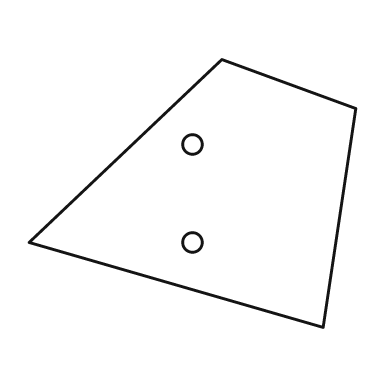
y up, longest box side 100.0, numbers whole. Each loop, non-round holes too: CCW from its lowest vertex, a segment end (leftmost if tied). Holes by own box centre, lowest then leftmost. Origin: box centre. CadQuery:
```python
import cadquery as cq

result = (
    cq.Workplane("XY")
    .moveTo(40.0, -41.0)
    .lineTo(50.0, 26.0)
    .lineTo(9.0, 41.0)
    .lineTo(-50.0, -15.0)
    .close()
    .moveTo(0.0, -15.0)
    .circle(3.0)
    .moveTo(0.0, 15.0)
    .circle(3.0)
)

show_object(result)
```